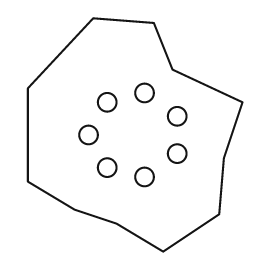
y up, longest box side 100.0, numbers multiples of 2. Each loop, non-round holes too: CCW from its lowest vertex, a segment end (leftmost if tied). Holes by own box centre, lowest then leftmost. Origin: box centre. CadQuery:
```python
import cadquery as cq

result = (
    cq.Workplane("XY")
    .moveTo(12.0, -50.0)
    .lineTo(36.0, -34.0)
    .lineTo(38.0, -10.0)
    .lineTo(46.0, 14.0)
    .lineTo(16.0, 28.0)
    .lineTo(8.0, 48.0)
    .lineTo(-18.0, 50.0)
    .lineTo(-46.0, 20.0)
    .lineTo(-46.0, -20.0)
    .lineTo(-26.0, -32.0)
    .lineTo(-8.0, -38.0)
    .close()
    .moveTo(4.0, -18.0)
    .circle(4.0)
    .moveTo(-12.0, -14.0)
    .circle(4.0)
    .moveTo(18.0, -8.0)
    .circle(4.0)
    .moveTo(-20.0, 0.0)
    .circle(4.0)
    .moveTo(18.0, 8.0)
    .circle(4.0)
    .moveTo(-12.0, 14.0)
    .circle(4.0)
    .moveTo(4.0, 18.0)
    .circle(4.0)
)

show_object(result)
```